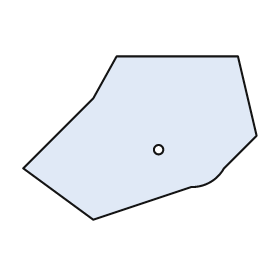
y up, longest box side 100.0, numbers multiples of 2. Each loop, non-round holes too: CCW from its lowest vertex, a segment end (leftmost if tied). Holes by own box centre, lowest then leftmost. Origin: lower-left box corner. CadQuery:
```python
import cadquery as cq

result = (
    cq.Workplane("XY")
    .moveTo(30.0, 0.0)
    .lineTo(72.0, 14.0)
    .threePointArc((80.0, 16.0), (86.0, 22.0))
    .lineTo(100.0, 36.0)
    .lineTo(92.0, 70.0)
    .lineTo(40.0, 70.0)
    .lineTo(30.0, 52.0)
    .lineTo(0.0, 22.0)
    .close()
    .moveTo(58.0, 30.0)
    .circle(2.0)
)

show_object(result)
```